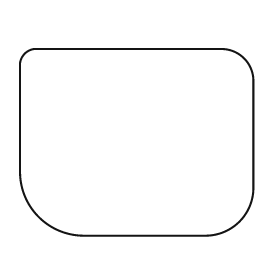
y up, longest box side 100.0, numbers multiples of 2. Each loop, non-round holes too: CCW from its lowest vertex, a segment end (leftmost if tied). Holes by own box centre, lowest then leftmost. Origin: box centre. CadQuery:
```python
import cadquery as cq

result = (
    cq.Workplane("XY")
    .moveTo(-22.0, -40.0)
    .lineTo(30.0, -40.0)
    .threePointArc((44.0, -34.0), (50.0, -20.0))
    .lineTo(50.0, 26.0)
    .threePointArc((46.0, 36.0), (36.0, 40.0))
    .lineTo(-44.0, 40.0)
    .threePointArc((-48.0, 38.0), (-50.0, 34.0))
    .lineTo(-50.0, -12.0)
    .threePointArc((-42.0, -32.0), (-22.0, -40.0))
    .close()
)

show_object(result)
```